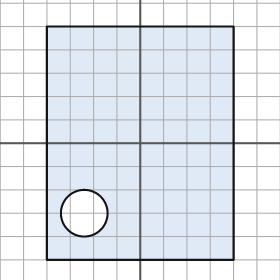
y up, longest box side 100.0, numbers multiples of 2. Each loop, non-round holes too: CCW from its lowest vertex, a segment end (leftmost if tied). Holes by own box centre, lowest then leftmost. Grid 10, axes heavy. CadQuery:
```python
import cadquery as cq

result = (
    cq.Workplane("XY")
    .moveTo(-40.0, -50.0)
    .lineTo(40.0, -50.0)
    .lineTo(40.0, 50.0)
    .lineTo(-40.0, 50.0)
    .close()
    .moveTo(-24.0, -30.0)
    .circle(10.0)
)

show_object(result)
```